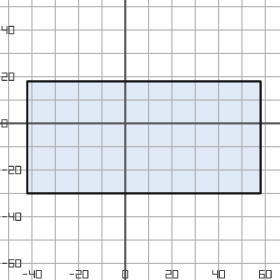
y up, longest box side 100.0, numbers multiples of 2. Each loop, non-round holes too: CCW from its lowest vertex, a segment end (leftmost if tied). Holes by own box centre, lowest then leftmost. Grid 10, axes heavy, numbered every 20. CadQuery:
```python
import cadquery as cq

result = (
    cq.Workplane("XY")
    .moveTo(-42.0, -30.0)
    .lineTo(58.0, -30.0)
    .lineTo(58.0, 18.0)
    .lineTo(-42.0, 18.0)
    .close()
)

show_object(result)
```